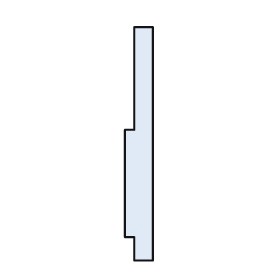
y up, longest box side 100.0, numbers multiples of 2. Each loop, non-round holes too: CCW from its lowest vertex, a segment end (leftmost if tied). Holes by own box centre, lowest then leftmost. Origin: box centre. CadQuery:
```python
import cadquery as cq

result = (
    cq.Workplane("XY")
    .moveTo(-2.0, -50.0)
    .lineTo(6.0, -50.0)
    .lineTo(6.0, 50.0)
    .lineTo(-2.0, 50.0)
    .lineTo(-2.0, 6.0)
    .lineTo(-6.0, 6.0)
    .lineTo(-6.0, -40.0)
    .lineTo(-2.0, -40.0)
    .close()
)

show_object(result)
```